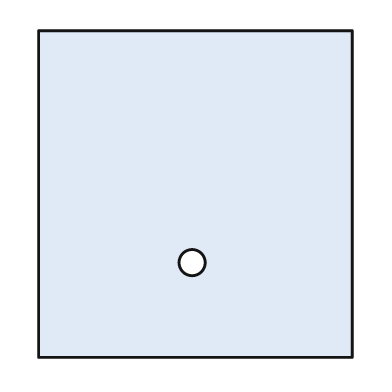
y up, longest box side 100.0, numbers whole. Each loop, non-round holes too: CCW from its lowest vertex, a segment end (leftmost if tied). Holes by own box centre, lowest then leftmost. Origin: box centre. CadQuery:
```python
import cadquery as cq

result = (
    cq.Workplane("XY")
    .moveTo(-48.0, -50.0)
    .lineTo(48.0, -50.0)
    .lineTo(48.0, 50.0)
    .lineTo(-48.0, 50.0)
    .close()
    .moveTo(-1.0, -21.0)
    .circle(4.0)
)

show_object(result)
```